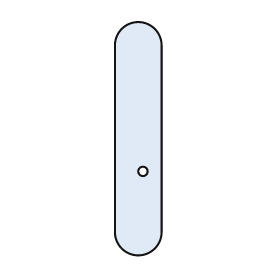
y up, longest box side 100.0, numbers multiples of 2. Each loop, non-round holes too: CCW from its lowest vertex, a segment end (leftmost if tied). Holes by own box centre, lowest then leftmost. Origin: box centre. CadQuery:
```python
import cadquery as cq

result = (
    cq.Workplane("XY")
    .moveTo(-10.0, -40.0)
    .threePointArc((0.0, -50.0), (10.0, -40.0))
    .lineTo(10.0, 40.0)
    .threePointArc((0.0, 50.0), (-10.0, 40.0))
    .close()
    .moveTo(2.0, -14.0)
    .circle(2.0)
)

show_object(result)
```